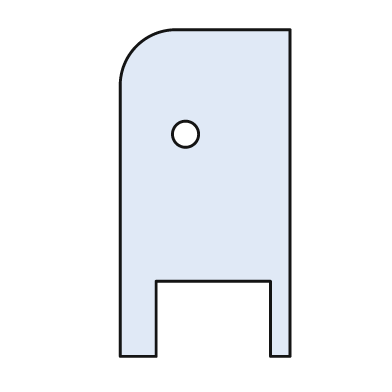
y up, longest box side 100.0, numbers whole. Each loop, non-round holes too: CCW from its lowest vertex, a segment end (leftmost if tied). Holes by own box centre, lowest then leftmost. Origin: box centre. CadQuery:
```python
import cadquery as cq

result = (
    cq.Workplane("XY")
    .moveTo(-26.0, -50.0)
    .lineTo(-15.0, -50.0)
    .lineTo(-15.0, -27.0)
    .lineTo(20.0, -27.0)
    .lineTo(20.0, -50.0)
    .lineTo(26.0, -50.0)
    .lineTo(26.0, 50.0)
    .lineTo(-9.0, 50.0)
    .threePointArc((-21.0, 45.0), (-26.0, 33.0))
    .close()
    .moveTo(-6.0, 18.0)
    .circle(4.0)
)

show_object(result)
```